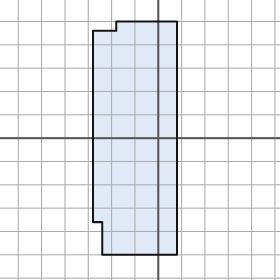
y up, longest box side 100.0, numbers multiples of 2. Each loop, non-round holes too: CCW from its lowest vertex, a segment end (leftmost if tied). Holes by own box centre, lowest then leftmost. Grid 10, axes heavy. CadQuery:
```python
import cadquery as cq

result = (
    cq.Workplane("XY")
    .moveTo(-24.0, -50.0)
    .lineTo(8.0, -50.0)
    .lineTo(8.0, 50.0)
    .lineTo(-18.0, 50.0)
    .lineTo(-18.0, 46.0)
    .lineTo(-28.0, 46.0)
    .lineTo(-28.0, -36.0)
    .lineTo(-24.0, -36.0)
    .close()
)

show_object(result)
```